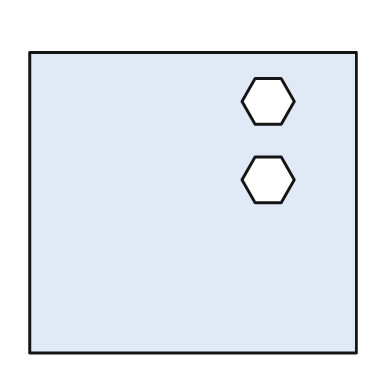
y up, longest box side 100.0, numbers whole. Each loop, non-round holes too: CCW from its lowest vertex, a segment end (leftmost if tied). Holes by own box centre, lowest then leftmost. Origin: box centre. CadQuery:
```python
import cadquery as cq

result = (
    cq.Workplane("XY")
    .moveTo(-50.0, -46.0)
    .lineTo(50.0, -46.0)
    .lineTo(50.0, 46.0)
    .lineTo(-50.0, 46.0)
    .close()
    .moveTo(19.0, 0.0)
    .lineTo(27.0, 0.0)
    .lineTo(31.0, 7.0)
    .lineTo(27.0, 14.0)
    .lineTo(19.0, 14.0)
    .lineTo(15.0, 7.0)
    .close()
    .moveTo(19.0, 24.0)
    .lineTo(27.0, 24.0)
    .lineTo(31.0, 31.0)
    .lineTo(27.0, 38.0)
    .lineTo(19.0, 38.0)
    .lineTo(15.0, 31.0)
    .close()
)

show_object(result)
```